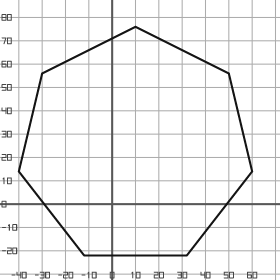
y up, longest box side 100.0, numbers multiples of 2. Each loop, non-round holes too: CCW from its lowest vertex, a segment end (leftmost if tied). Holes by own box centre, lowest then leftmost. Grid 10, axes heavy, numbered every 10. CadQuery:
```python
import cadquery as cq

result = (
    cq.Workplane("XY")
    .moveTo(-12.0, -22.0)
    .lineTo(32.0, -22.0)
    .lineTo(60.0, 14.0)
    .lineTo(50.0, 56.0)
    .lineTo(10.0, 76.0)
    .lineTo(-30.0, 56.0)
    .lineTo(-40.0, 14.0)
    .close()
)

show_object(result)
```